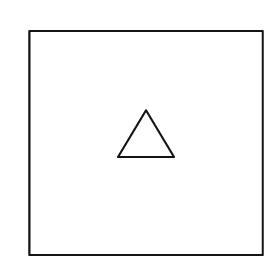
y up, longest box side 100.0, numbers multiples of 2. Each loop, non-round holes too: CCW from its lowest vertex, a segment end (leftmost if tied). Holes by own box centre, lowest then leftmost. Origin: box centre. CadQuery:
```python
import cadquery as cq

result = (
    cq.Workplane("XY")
    .moveTo(-50.0, -48.0)
    .lineTo(50.0, -48.0)
    .lineTo(50.0, 48.0)
    .lineTo(-50.0, 48.0)
    .close()
    .moveTo(-12.0, -6.0)
    .lineTo(12.0, -6.0)
    .lineTo(0.0, 14.0)
    .close()
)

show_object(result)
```